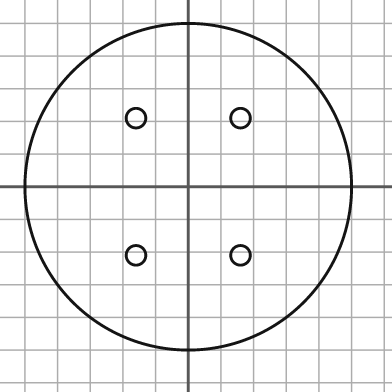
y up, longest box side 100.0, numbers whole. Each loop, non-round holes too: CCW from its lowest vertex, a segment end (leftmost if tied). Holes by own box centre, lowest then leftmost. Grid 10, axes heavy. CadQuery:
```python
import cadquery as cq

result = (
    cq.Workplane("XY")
    .moveTo(0.0, 0.0)
    .circle(50.0)
    .moveTo(-16.0, -21.0)
    .circle(3.0)
    .moveTo(16.0, -21.0)
    .circle(3.0)
    .moveTo(-16.0, 21.0)
    .circle(3.0)
    .moveTo(16.0, 21.0)
    .circle(3.0)
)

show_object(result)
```